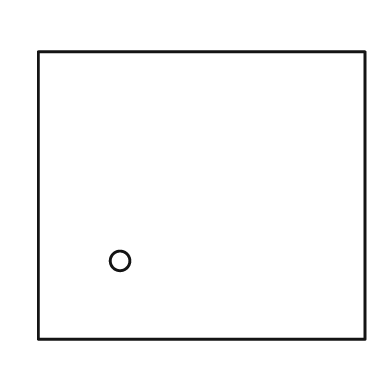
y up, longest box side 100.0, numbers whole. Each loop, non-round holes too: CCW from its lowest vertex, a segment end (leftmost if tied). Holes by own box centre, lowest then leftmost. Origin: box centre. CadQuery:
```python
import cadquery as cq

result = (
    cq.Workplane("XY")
    .moveTo(-50.0, -44.0)
    .lineTo(50.0, -44.0)
    .lineTo(50.0, 44.0)
    .lineTo(-50.0, 44.0)
    .close()
    .moveTo(-25.0, -20.0)
    .circle(3.0)
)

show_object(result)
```